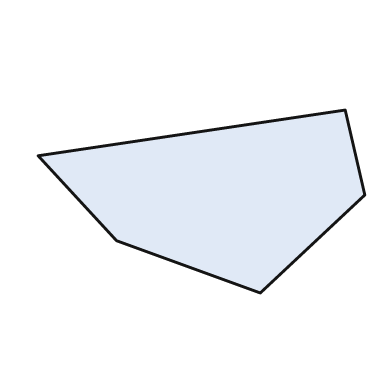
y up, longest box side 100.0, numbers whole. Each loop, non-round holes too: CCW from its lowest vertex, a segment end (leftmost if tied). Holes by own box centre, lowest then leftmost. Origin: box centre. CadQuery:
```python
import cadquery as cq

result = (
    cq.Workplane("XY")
    .moveTo(18.0, -28.0)
    .lineTo(50.0, 2.0)
    .lineTo(44.0, 28.0)
    .lineTo(-50.0, 14.0)
    .lineTo(-26.0, -12.0)
    .close()
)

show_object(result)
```